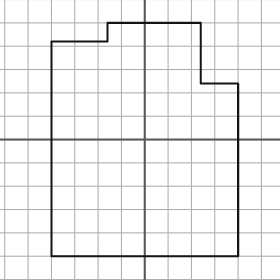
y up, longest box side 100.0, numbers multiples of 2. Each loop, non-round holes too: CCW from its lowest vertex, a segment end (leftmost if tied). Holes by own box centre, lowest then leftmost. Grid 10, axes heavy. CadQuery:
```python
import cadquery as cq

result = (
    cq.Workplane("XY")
    .moveTo(-40.0, -50.0)
    .lineTo(40.0, -50.0)
    .lineTo(40.0, 24.0)
    .lineTo(24.0, 24.0)
    .lineTo(24.0, 50.0)
    .lineTo(-16.0, 50.0)
    .lineTo(-16.0, 42.0)
    .lineTo(-40.0, 42.0)
    .close()
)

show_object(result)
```